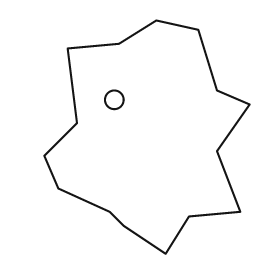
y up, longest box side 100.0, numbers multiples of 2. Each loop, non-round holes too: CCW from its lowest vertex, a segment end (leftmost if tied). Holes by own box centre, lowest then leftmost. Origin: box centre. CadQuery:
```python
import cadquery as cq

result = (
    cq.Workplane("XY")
    .moveTo(8.0, -50.0)
    .lineTo(18.0, -34.0)
    .lineTo(40.0, -32.0)
    .lineTo(30.0, -6.0)
    .lineTo(44.0, 14.0)
    .lineTo(30.0, 20.0)
    .lineTo(22.0, 46.0)
    .lineTo(4.0, 50.0)
    .lineTo(-12.0, 40.0)
    .lineTo(-34.0, 38.0)
    .lineTo(-30.0, 6.0)
    .lineTo(-44.0, -8.0)
    .lineTo(-38.0, -22.0)
    .lineTo(-16.0, -32.0)
    .lineTo(-10.0, -38.0)
    .close()
    .moveTo(-14.0, 16.0)
    .circle(4.0)
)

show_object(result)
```